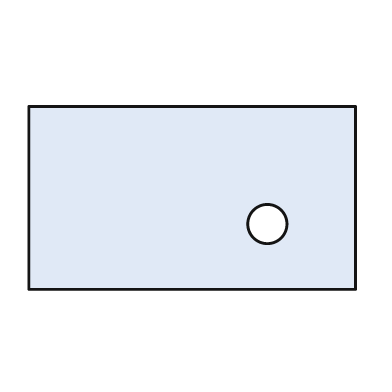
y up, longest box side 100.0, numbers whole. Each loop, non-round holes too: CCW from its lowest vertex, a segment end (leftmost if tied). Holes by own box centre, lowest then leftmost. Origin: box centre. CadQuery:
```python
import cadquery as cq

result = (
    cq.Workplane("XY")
    .moveTo(-50.0, -28.0)
    .lineTo(50.0, -28.0)
    .lineTo(50.0, 28.0)
    .lineTo(-50.0, 28.0)
    .close()
    .moveTo(23.0, -8.0)
    .circle(6.0)
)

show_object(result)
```